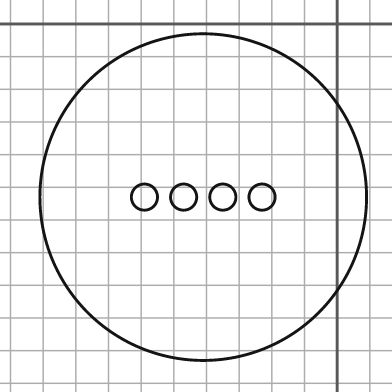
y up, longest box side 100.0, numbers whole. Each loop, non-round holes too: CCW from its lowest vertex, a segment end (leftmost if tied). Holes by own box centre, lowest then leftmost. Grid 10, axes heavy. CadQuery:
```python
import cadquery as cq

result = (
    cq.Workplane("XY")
    .moveTo(-41.0, -53.0)
    .circle(50.0)
    .moveTo(-59.0, -53.0)
    .circle(4.0)
    .moveTo(-47.0, -53.0)
    .circle(4.0)
    .moveTo(-35.0, -53.0)
    .circle(4.0)
    .moveTo(-23.0, -53.0)
    .circle(4.0)
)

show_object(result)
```